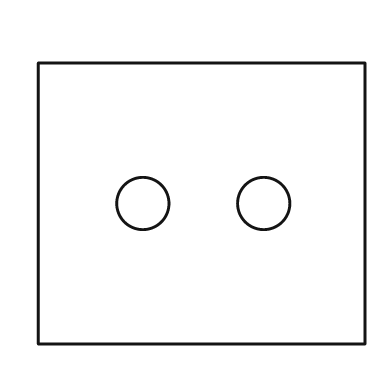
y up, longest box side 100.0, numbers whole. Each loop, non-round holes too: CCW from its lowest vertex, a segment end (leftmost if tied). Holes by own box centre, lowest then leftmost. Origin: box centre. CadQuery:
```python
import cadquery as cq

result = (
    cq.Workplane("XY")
    .moveTo(-50.0, -43.0)
    .lineTo(50.0, -43.0)
    .lineTo(50.0, 43.0)
    .lineTo(-50.0, 43.0)
    .close()
    .moveTo(-18.0, 0.0)
    .circle(8.0)
    .moveTo(19.0, 0.0)
    .circle(8.0)
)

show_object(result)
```